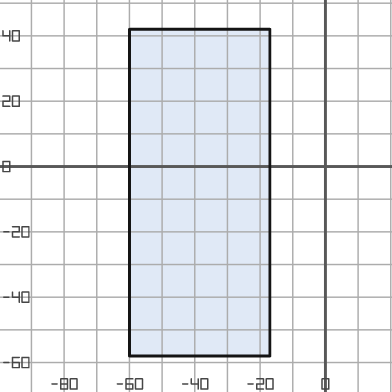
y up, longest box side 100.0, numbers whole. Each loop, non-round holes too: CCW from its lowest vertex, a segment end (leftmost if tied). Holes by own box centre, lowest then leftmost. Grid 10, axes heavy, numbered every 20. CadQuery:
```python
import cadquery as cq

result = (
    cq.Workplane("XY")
    .moveTo(-60.0, -58.0)
    .lineTo(-17.0, -58.0)
    .lineTo(-17.0, 42.0)
    .lineTo(-60.0, 42.0)
    .close()
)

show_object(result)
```